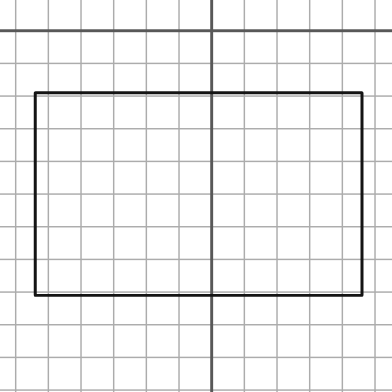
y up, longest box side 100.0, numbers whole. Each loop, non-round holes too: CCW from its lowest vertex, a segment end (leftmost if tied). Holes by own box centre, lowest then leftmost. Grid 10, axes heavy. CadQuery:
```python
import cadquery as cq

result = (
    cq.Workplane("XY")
    .moveTo(-54.0, -81.0)
    .lineTo(46.0, -81.0)
    .lineTo(46.0, -19.0)
    .lineTo(-54.0, -19.0)
    .close()
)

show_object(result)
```